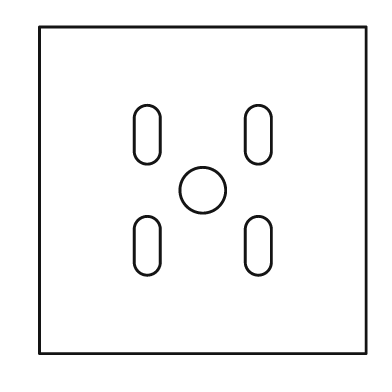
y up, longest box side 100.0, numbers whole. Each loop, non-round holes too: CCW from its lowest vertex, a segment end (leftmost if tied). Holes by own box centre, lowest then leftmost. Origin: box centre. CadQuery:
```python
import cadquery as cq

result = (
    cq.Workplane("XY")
    .moveTo(-50.0, -50.0)
    .lineTo(50.0, -50.0)
    .lineTo(50.0, 50.0)
    .lineTo(-50.0, 50.0)
    .close()
    .moveTo(-21.0, -22.0)
    .threePointArc((-17.0, -26.0), (-13.0, -22.0))
    .lineTo(-13.0, -12.0)
    .threePointArc((-17.0, -8.0), (-21.0, -12.0))
    .close()
    .moveTo(13.0, -22.0)
    .threePointArc((17.0, -26.0), (21.0, -22.0))
    .lineTo(21.0, -12.0)
    .threePointArc((17.0, -8.0), (13.0, -12.0))
    .close()
    .moveTo(0.0, 0.0)
    .circle(7.0)
    .moveTo(-21.0, 12.0)
    .threePointArc((-17.0, 8.0), (-13.0, 12.0))
    .lineTo(-13.0, 22.0)
    .threePointArc((-17.0, 26.0), (-21.0, 22.0))
    .close()
    .moveTo(13.0, 12.0)
    .threePointArc((17.0, 8.0), (21.0, 12.0))
    .lineTo(21.0, 22.0)
    .threePointArc((17.0, 26.0), (13.0, 22.0))
    .close()
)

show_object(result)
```